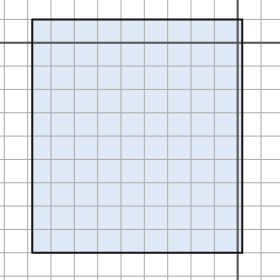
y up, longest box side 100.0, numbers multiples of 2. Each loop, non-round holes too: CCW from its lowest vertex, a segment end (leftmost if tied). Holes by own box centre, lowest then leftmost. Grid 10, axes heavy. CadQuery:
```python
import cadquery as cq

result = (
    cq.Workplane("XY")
    .moveTo(-88.0, -90.0)
    .lineTo(2.0, -90.0)
    .lineTo(2.0, 10.0)
    .lineTo(-88.0, 10.0)
    .close()
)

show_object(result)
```